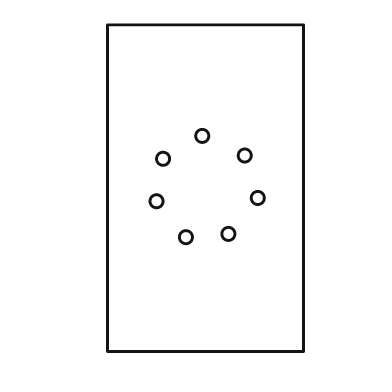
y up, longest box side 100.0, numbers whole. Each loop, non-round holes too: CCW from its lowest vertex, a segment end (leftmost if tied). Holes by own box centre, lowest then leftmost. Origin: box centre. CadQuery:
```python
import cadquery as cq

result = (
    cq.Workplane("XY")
    .moveTo(-30.0, -50.0)
    .lineTo(30.0, -50.0)
    .lineTo(30.0, 50.0)
    .lineTo(-30.0, 50.0)
    .close()
    .moveTo(-6.0, -15.0)
    .circle(2.0)
    .moveTo(7.0, -14.0)
    .circle(2.0)
    .moveTo(-15.0, -4.0)
    .circle(2.0)
    .moveTo(16.0, -3.0)
    .circle(2.0)
    .moveTo(-13.0, 9.0)
    .circle(2.0)
    .moveTo(12.0, 10.0)
    .circle(2.0)
    .moveTo(-1.0, 16.0)
    .circle(2.0)
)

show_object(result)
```